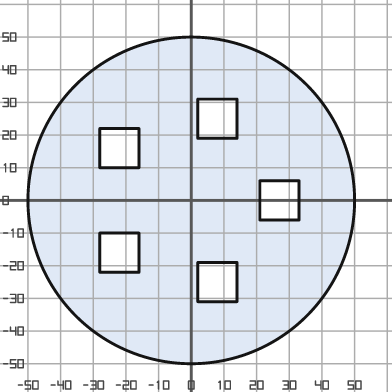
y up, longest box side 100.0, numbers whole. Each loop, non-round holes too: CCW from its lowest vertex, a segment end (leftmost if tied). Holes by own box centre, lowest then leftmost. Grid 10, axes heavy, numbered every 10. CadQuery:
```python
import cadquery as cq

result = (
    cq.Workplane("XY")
    .moveTo(0.0, 0.0)
    .circle(50.0)
    .moveTo(2.0, -31.0)
    .lineTo(14.0, -31.0)
    .lineTo(14.0, -19.0)
    .lineTo(2.0, -19.0)
    .close()
    .moveTo(-28.0, -22.0)
    .lineTo(-16.0, -22.0)
    .lineTo(-16.0, -10.0)
    .lineTo(-28.0, -10.0)
    .close()
    .moveTo(21.0, -6.0)
    .lineTo(33.0, -6.0)
    .lineTo(33.0, 6.0)
    .lineTo(21.0, 6.0)
    .close()
    .moveTo(-28.0, 10.0)
    .lineTo(-16.0, 10.0)
    .lineTo(-16.0, 22.0)
    .lineTo(-28.0, 22.0)
    .close()
    .moveTo(2.0, 19.0)
    .lineTo(14.0, 19.0)
    .lineTo(14.0, 31.0)
    .lineTo(2.0, 31.0)
    .close()
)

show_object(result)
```